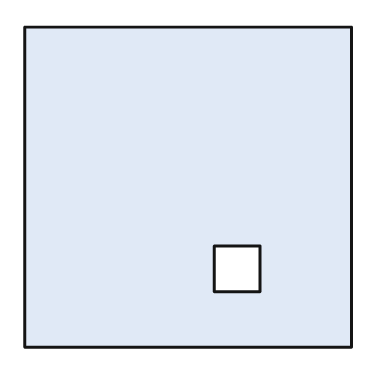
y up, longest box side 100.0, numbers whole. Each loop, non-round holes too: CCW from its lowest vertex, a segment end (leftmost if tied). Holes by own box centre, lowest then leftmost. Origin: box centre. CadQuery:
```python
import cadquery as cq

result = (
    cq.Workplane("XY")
    .moveTo(-50.0, -49.0)
    .lineTo(50.0, -49.0)
    .lineTo(50.0, 49.0)
    .lineTo(-50.0, 49.0)
    .close()
    .moveTo(8.0, -32.0)
    .lineTo(22.0, -32.0)
    .lineTo(22.0, -18.0)
    .lineTo(8.0, -18.0)
    .close()
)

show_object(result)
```